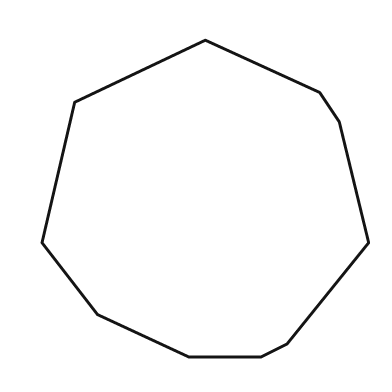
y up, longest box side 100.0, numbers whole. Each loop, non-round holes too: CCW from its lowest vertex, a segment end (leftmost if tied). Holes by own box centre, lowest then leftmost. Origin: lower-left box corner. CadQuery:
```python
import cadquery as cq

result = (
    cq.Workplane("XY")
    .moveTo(45.0, 0.0)
    .lineTo(67.0, 0.0)
    .lineTo(75.0, 4.0)
    .lineTo(100.0, 35.0)
    .lineTo(91.0, 72.0)
    .lineTo(85.0, 81.0)
    .lineTo(50.0, 97.0)
    .lineTo(10.0, 78.0)
    .lineTo(0.0, 35.0)
    .lineTo(17.0, 13.0)
    .close()
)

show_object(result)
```